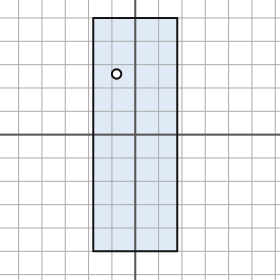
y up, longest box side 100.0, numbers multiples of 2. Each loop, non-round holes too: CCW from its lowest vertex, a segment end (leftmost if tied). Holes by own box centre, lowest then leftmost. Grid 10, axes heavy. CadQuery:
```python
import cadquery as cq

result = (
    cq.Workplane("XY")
    .moveTo(-18.0, -50.0)
    .lineTo(18.0, -50.0)
    .lineTo(18.0, 50.0)
    .lineTo(-18.0, 50.0)
    .close()
    .moveTo(-8.0, 26.0)
    .circle(2.0)
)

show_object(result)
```